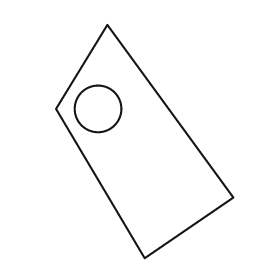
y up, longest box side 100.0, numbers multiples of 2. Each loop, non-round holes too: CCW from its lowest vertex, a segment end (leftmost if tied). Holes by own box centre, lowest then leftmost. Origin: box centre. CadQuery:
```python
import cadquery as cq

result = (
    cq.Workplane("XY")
    .moveTo(0.0, -50.0)
    .lineTo(38.0, -24.0)
    .lineTo(-16.0, 50.0)
    .lineTo(-38.0, 14.0)
    .close()
    .moveTo(-20.0, 14.0)
    .circle(10.0)
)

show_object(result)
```